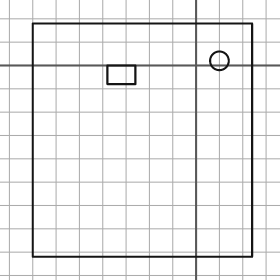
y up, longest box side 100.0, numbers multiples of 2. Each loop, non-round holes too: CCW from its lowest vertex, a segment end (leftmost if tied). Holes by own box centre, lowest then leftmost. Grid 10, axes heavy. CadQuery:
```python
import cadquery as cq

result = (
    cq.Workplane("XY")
    .moveTo(-70.0, -82.0)
    .lineTo(24.0, -82.0)
    .lineTo(24.0, 18.0)
    .lineTo(-70.0, 18.0)
    .close()
    .moveTo(-38.0, -8.0)
    .lineTo(-26.0, -8.0)
    .lineTo(-26.0, 0.0)
    .lineTo(-38.0, 0.0)
    .close()
    .moveTo(10.0, 2.0)
    .circle(4.0)
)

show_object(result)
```